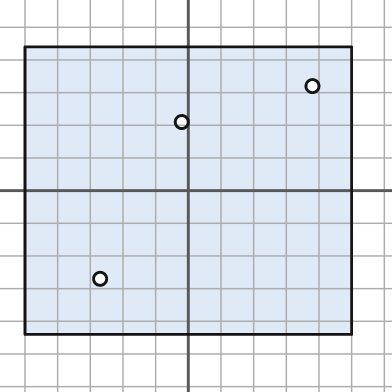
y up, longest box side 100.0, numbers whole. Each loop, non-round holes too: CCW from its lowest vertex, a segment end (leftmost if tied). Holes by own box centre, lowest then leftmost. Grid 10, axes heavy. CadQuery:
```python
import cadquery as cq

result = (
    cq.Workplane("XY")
    .moveTo(-50.0, -44.0)
    .lineTo(50.0, -44.0)
    .lineTo(50.0, 44.0)
    .lineTo(-50.0, 44.0)
    .close()
    .moveTo(-27.0, -27.0)
    .circle(2.0)
    .moveTo(-2.0, 21.0)
    .circle(2.0)
    .moveTo(38.0, 32.0)
    .circle(2.0)
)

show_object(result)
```